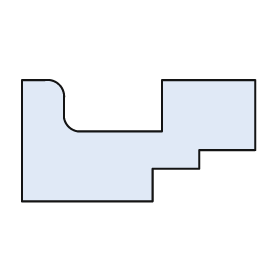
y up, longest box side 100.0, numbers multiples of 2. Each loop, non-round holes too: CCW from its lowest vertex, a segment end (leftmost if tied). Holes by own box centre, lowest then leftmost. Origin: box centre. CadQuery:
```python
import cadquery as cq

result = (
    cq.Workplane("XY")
    .moveTo(-50.0, -26.0)
    .lineTo(6.0, -26.0)
    .lineTo(6.0, -12.0)
    .lineTo(26.0, -12.0)
    .lineTo(26.0, -4.0)
    .lineTo(50.0, -4.0)
    .lineTo(50.0, 26.0)
    .lineTo(10.0, 26.0)
    .lineTo(10.0, 4.0)
    .lineTo(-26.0, 4.0)
    .threePointArc((-30.0, 6.0), (-32.0, 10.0))
    .lineTo(-32.0, 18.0)
    .threePointArc((-34.0, 24.0), (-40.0, 26.0))
    .lineTo(-50.0, 26.0)
    .close()
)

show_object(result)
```